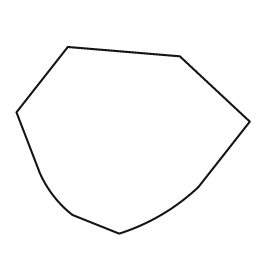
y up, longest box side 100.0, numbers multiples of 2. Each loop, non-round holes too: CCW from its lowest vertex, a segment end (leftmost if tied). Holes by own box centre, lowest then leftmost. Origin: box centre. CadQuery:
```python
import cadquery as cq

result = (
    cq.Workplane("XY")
    .moveTo(-6.0, -40.0)
    .threePointArc((12.0, -32.0), (28.0, -20.0))
    .lineTo(50.0, 8.0)
    .lineTo(20.0, 36.0)
    .lineTo(-28.0, 40.0)
    .lineTo(-50.0, 12.0)
    .lineTo(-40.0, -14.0)
    .threePointArc((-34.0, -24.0), (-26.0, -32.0))
    .close()
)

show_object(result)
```